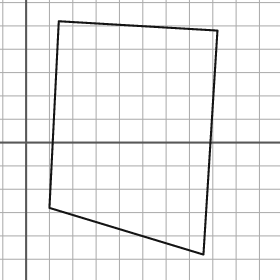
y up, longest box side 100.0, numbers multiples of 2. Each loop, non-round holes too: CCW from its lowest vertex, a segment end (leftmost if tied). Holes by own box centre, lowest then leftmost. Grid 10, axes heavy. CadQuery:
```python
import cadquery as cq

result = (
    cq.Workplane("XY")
    .moveTo(76.0, -48.0)
    .lineTo(82.0, 48.0)
    .lineTo(14.0, 52.0)
    .lineTo(10.0, -28.0)
    .close()
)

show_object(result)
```